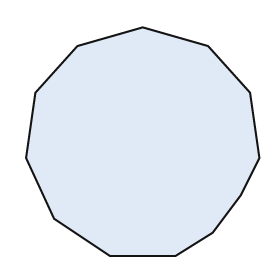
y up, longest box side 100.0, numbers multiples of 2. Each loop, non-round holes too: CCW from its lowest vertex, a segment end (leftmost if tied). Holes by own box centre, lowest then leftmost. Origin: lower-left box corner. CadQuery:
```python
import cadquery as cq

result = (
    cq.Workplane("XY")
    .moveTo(36.0, 0.0)
    .lineTo(64.0, 0.0)
    .lineTo(80.0, 10.0)
    .lineTo(92.0, 26.0)
    .lineTo(100.0, 42.0)
    .lineTo(96.0, 70.0)
    .lineTo(78.0, 90.0)
    .lineTo(50.0, 98.0)
    .lineTo(22.0, 90.0)
    .lineTo(4.0, 70.0)
    .lineTo(0.0, 42.0)
    .lineTo(12.0, 16.0)
    .close()
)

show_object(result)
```